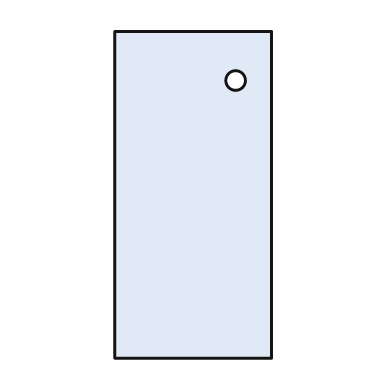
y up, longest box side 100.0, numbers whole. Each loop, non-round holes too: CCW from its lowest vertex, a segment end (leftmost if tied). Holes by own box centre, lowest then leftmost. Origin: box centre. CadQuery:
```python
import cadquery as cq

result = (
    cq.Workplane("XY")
    .moveTo(-24.0, -50.0)
    .lineTo(24.0, -50.0)
    .lineTo(24.0, 50.0)
    .lineTo(-24.0, 50.0)
    .close()
    .moveTo(13.0, 35.0)
    .circle(3.0)
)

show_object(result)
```